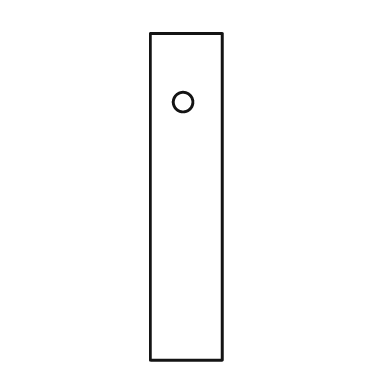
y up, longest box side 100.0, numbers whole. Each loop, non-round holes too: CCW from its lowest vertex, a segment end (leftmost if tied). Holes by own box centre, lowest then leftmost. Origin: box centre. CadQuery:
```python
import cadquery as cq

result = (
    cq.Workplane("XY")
    .moveTo(-11.0, -50.0)
    .lineTo(11.0, -50.0)
    .lineTo(11.0, 50.0)
    .lineTo(-11.0, 50.0)
    .close()
    .moveTo(-1.0, 29.0)
    .circle(3.0)
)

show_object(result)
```